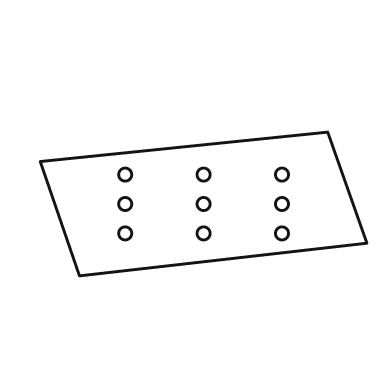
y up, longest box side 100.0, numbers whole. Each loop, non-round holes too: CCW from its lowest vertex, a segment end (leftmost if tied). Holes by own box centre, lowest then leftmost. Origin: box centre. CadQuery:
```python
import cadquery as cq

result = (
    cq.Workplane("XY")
    .moveTo(-38.0, -22.0)
    .lineTo(50.0, -12.0)
    .lineTo(38.0, 22.0)
    .lineTo(-50.0, 13.0)
    .close()
    .moveTo(-24.0, -9.0)
    .circle(2.0)
    .moveTo(0.0, -9.0)
    .circle(2.0)
    .moveTo(24.0, -9.0)
    .circle(2.0)
    .moveTo(-24.0, 0.0)
    .circle(2.0)
    .moveTo(0.0, 0.0)
    .circle(2.0)
    .moveTo(24.0, 0.0)
    .circle(2.0)
    .moveTo(-24.0, 9.0)
    .circle(2.0)
    .moveTo(0.0, 9.0)
    .circle(2.0)
    .moveTo(24.0, 9.0)
    .circle(2.0)
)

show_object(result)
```